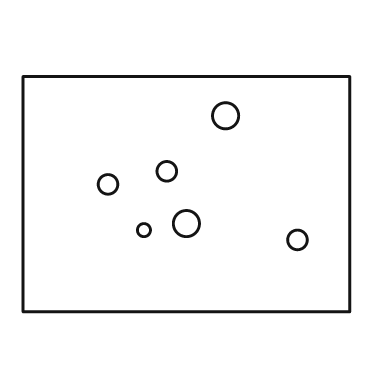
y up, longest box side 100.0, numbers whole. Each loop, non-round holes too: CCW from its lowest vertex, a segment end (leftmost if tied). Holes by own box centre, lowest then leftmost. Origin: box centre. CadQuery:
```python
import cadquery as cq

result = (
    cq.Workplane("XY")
    .moveTo(-50.0, -36.0)
    .lineTo(50.0, -36.0)
    .lineTo(50.0, 36.0)
    .lineTo(-50.0, 36.0)
    .close()
    .moveTo(34.0, -14.0)
    .circle(3.0)
    .moveTo(-13.0, -11.0)
    .circle(2.0)
    .moveTo(0.0, -9.0)
    .circle(4.0)
    .moveTo(-24.0, 3.0)
    .circle(3.0)
    .moveTo(-6.0, 7.0)
    .circle(3.0)
    .moveTo(12.0, 24.0)
    .circle(4.0)
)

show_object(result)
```